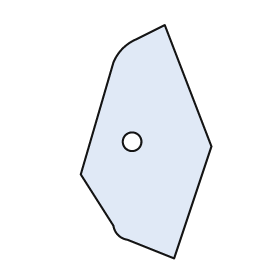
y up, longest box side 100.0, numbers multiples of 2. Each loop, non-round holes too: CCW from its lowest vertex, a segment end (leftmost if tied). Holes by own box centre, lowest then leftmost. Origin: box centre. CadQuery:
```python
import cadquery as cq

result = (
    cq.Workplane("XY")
    .moveTo(12.0, -50.0)
    .lineTo(28.0, -2.0)
    .lineTo(8.0, 50.0)
    .lineTo(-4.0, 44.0)
    .threePointArc((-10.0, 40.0), (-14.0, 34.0))
    .lineTo(-28.0, -14.0)
    .lineTo(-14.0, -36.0)
    .threePointArc((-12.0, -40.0), (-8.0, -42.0))
    .close()
    .moveTo(-6.0, 0.0)
    .circle(4.0)
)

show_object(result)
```